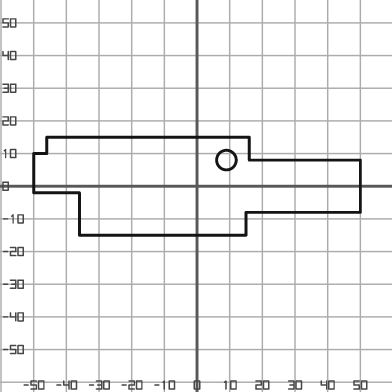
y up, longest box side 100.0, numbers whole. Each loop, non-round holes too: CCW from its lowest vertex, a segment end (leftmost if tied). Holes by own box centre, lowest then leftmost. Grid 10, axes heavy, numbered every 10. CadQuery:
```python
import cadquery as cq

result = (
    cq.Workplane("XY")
    .moveTo(-36.0, -15.0)
    .lineTo(15.0, -15.0)
    .lineTo(15.0, -8.0)
    .lineTo(50.0, -8.0)
    .lineTo(50.0, 8.0)
    .lineTo(16.0, 8.0)
    .lineTo(16.0, 15.0)
    .lineTo(-46.0, 15.0)
    .lineTo(-46.0, 10.0)
    .lineTo(-50.0, 10.0)
    .lineTo(-50.0, -2.0)
    .lineTo(-36.0, -2.0)
    .close()
    .moveTo(9.0, 8.0)
    .circle(3.0)
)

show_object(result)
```